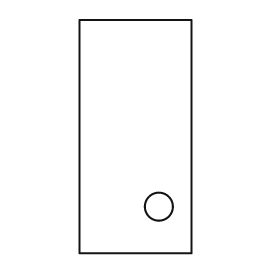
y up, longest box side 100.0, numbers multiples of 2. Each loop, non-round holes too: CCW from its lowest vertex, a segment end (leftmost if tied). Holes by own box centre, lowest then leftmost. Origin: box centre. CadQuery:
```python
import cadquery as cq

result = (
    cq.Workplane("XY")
    .moveTo(-24.0, -50.0)
    .lineTo(24.0, -50.0)
    .lineTo(24.0, 50.0)
    .lineTo(-24.0, 50.0)
    .close()
    .moveTo(10.0, -30.0)
    .circle(6.0)
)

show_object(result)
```